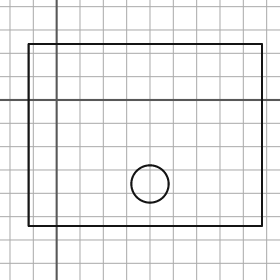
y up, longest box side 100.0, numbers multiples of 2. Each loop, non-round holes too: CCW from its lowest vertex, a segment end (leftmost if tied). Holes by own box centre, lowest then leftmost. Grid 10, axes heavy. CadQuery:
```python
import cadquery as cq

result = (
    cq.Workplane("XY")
    .moveTo(-12.0, -54.0)
    .lineTo(88.0, -54.0)
    .lineTo(88.0, 24.0)
    .lineTo(-12.0, 24.0)
    .close()
    .moveTo(40.0, -36.0)
    .circle(8.0)
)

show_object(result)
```